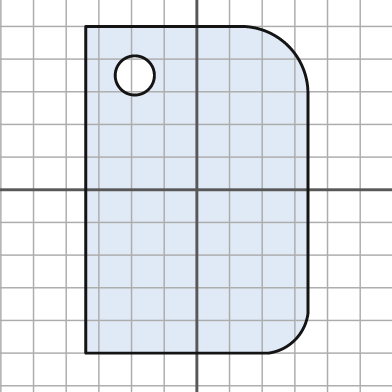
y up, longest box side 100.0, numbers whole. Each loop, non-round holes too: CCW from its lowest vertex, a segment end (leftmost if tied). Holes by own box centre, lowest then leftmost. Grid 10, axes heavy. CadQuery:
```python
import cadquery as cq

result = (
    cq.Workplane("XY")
    .moveTo(-34.0, -50.0)
    .lineTo(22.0, -50.0)
    .threePointArc((30.0, -46.0), (34.0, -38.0))
    .lineTo(34.0, 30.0)
    .threePointArc((28.0, 44.0), (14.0, 50.0))
    .lineTo(-34.0, 50.0)
    .close()
    .moveTo(-19.0, 35.0)
    .circle(6.0)
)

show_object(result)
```